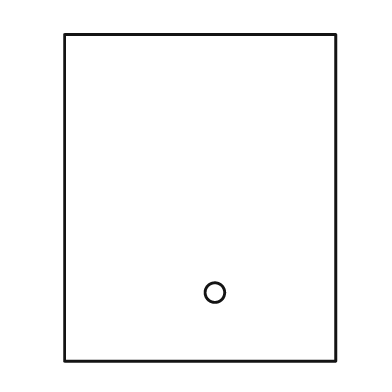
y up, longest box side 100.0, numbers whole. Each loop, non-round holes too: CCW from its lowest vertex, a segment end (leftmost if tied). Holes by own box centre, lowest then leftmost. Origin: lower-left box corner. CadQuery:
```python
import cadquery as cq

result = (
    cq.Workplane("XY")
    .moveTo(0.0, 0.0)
    .lineTo(83.0, 0.0)
    .lineTo(83.0, 100.0)
    .lineTo(0.0, 100.0)
    .close()
    .moveTo(46.0, 21.0)
    .circle(3.0)
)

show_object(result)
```